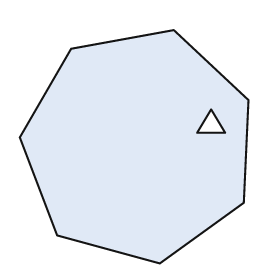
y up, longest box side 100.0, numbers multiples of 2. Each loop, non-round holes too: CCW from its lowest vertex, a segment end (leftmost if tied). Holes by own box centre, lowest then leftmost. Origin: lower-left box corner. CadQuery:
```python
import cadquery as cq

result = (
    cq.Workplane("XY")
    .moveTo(60.0, 0.0)
    .lineTo(96.0, 26.0)
    .lineTo(98.0, 70.0)
    .lineTo(66.0, 100.0)
    .lineTo(22.0, 92.0)
    .lineTo(0.0, 54.0)
    .lineTo(16.0, 12.0)
    .close()
    .moveTo(76.0, 56.0)
    .lineTo(88.0, 56.0)
    .lineTo(82.0, 66.0)
    .close()
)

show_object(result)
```